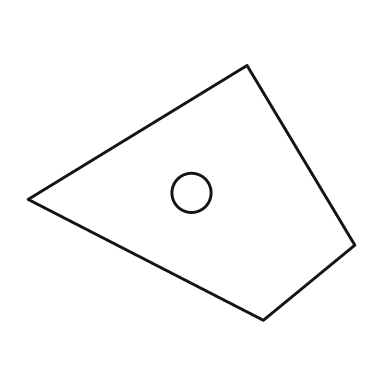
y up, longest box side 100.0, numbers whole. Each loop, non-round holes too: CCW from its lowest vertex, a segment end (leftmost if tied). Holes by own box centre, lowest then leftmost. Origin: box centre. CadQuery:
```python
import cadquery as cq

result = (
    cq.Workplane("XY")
    .moveTo(22.0, -39.0)
    .lineTo(50.0, -16.0)
    .lineTo(17.0, 39.0)
    .lineTo(-50.0, -2.0)
    .close()
    .moveTo(0.0, 0.0)
    .circle(6.0)
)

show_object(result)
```